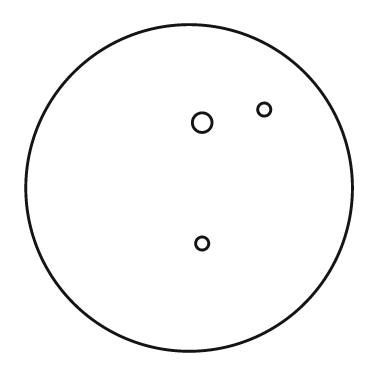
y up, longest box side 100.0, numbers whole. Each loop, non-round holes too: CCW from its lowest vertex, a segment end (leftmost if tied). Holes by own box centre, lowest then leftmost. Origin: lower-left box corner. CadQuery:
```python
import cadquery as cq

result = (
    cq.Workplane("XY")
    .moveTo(50.0, 50.0)
    .circle(50.0)
    .moveTo(54.0, 33.0)
    .circle(2.0)
    .moveTo(54.0, 70.0)
    .circle(3.0)
    .moveTo(73.0, 74.0)
    .circle(2.0)
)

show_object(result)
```